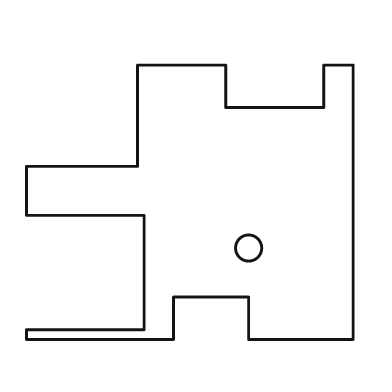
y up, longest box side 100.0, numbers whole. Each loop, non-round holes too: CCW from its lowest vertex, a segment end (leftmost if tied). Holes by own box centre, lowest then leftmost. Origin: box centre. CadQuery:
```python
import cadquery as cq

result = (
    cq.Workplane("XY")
    .moveTo(-50.0, -42.0)
    .lineTo(-5.0, -42.0)
    .lineTo(-5.0, -29.0)
    .lineTo(18.0, -29.0)
    .lineTo(18.0, -42.0)
    .lineTo(50.0, -42.0)
    .lineTo(50.0, 42.0)
    .lineTo(41.0, 42.0)
    .lineTo(41.0, 29.0)
    .lineTo(11.0, 29.0)
    .lineTo(11.0, 42.0)
    .lineTo(-16.0, 42.0)
    .lineTo(-16.0, 11.0)
    .lineTo(-50.0, 11.0)
    .lineTo(-50.0, -4.0)
    .lineTo(-14.0, -4.0)
    .lineTo(-14.0, -39.0)
    .lineTo(-50.0, -39.0)
    .close()
    .moveTo(18.0, -14.0)
    .circle(4.0)
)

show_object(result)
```